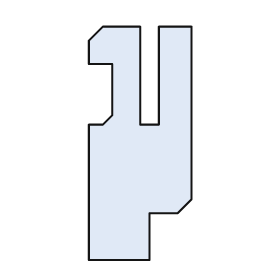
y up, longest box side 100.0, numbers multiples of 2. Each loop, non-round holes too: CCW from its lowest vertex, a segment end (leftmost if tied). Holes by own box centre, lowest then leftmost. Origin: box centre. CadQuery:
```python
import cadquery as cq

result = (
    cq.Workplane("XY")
    .moveTo(-22.0, -50.0)
    .lineTo(4.0, -50.0)
    .lineTo(4.0, -30.0)
    .lineTo(16.0, -30.0)
    .lineTo(22.0, -24.0)
    .lineTo(22.0, 50.0)
    .lineTo(8.0, 50.0)
    .lineTo(8.0, 8.0)
    .lineTo(0.0, 8.0)
    .lineTo(0.0, 50.0)
    .lineTo(-16.0, 50.0)
    .lineTo(-22.0, 44.0)
    .lineTo(-22.0, 34.0)
    .lineTo(-12.0, 34.0)
    .lineTo(-12.0, 12.0)
    .lineTo(-16.0, 8.0)
    .lineTo(-22.0, 8.0)
    .close()
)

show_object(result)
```